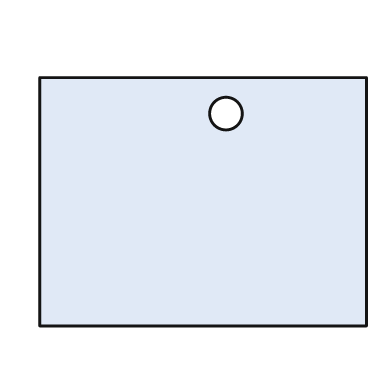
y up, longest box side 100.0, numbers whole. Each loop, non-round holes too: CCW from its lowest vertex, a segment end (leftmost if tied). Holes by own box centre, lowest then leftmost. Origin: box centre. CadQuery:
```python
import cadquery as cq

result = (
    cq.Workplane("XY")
    .moveTo(-50.0, -38.0)
    .lineTo(50.0, -38.0)
    .lineTo(50.0, 38.0)
    .lineTo(-50.0, 38.0)
    .close()
    .moveTo(7.0, 27.0)
    .circle(5.0)
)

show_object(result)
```